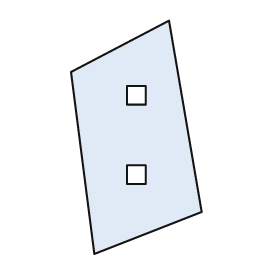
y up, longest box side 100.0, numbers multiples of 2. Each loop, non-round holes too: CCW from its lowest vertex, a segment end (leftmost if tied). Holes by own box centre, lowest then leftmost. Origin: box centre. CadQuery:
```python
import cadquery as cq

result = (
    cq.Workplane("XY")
    .moveTo(-18.0, -50.0)
    .lineTo(28.0, -32.0)
    .lineTo(14.0, 50.0)
    .lineTo(-28.0, 28.0)
    .close()
    .moveTo(-4.0, -20.0)
    .lineTo(4.0, -20.0)
    .lineTo(4.0, -12.0)
    .lineTo(-4.0, -12.0)
    .close()
    .moveTo(-4.0, 14.0)
    .lineTo(4.0, 14.0)
    .lineTo(4.0, 22.0)
    .lineTo(-4.0, 22.0)
    .close()
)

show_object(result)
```